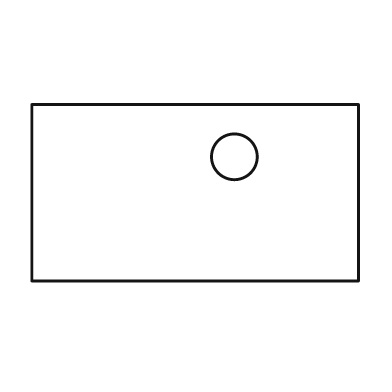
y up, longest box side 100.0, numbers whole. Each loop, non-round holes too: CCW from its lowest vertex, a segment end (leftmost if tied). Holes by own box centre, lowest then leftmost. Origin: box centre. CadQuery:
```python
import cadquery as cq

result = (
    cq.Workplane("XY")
    .moveTo(-50.0, -27.0)
    .lineTo(50.0, -27.0)
    .lineTo(50.0, 27.0)
    .lineTo(-50.0, 27.0)
    .close()
    .moveTo(12.0, 11.0)
    .circle(7.0)
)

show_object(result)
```